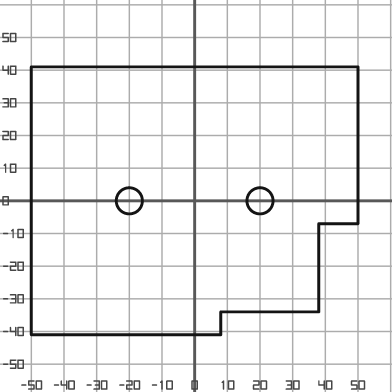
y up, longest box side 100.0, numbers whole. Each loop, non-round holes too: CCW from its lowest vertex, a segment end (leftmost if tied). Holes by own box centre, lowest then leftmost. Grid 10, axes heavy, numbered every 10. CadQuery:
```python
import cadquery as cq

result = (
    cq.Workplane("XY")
    .moveTo(-50.0, -41.0)
    .lineTo(8.0, -41.0)
    .lineTo(8.0, -34.0)
    .lineTo(38.0, -34.0)
    .lineTo(38.0, -7.0)
    .lineTo(50.0, -7.0)
    .lineTo(50.0, 41.0)
    .lineTo(-50.0, 41.0)
    .close()
    .moveTo(-20.0, 0.0)
    .circle(4.0)
    .moveTo(20.0, 0.0)
    .circle(4.0)
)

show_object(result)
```